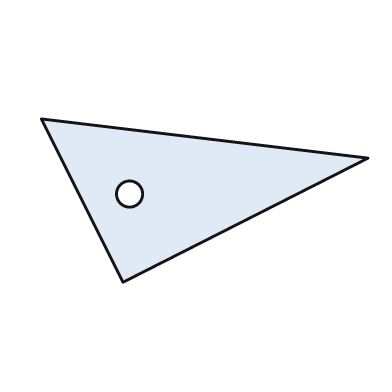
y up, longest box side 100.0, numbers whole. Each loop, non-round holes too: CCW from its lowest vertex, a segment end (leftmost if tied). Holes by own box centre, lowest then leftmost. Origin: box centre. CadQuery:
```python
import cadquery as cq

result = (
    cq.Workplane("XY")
    .moveTo(-25.0, -25.0)
    .lineTo(50.0, 13.0)
    .lineTo(-50.0, 25.0)
    .close()
    .moveTo(-23.0, 2.0)
    .circle(4.0)
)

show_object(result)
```